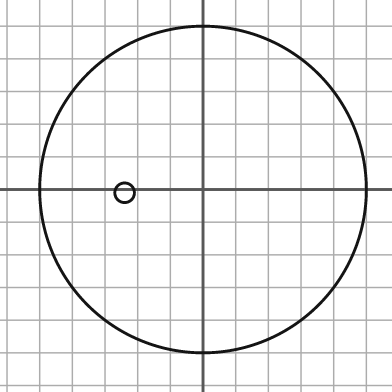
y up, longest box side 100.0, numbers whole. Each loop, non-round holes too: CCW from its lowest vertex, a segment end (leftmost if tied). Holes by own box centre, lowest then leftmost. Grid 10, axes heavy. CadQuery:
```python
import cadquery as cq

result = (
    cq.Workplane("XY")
    .moveTo(0.0, 0.0)
    .circle(50.0)
    .moveTo(-24.0, -1.0)
    .circle(3.0)
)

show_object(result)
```